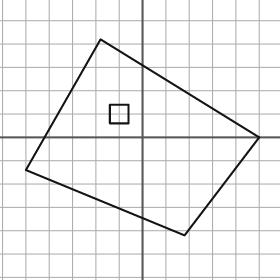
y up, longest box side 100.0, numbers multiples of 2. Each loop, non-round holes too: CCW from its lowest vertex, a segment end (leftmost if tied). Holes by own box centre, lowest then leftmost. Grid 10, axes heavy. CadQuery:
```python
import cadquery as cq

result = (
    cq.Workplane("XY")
    .moveTo(18.0, -42.0)
    .lineTo(50.0, 0.0)
    .lineTo(-18.0, 42.0)
    .lineTo(-50.0, -14.0)
    .close()
    .moveTo(-14.0, 6.0)
    .lineTo(-6.0, 6.0)
    .lineTo(-6.0, 14.0)
    .lineTo(-14.0, 14.0)
    .close()
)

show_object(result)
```